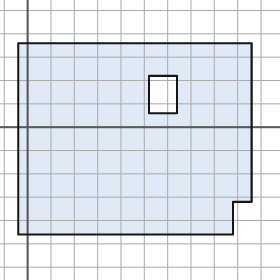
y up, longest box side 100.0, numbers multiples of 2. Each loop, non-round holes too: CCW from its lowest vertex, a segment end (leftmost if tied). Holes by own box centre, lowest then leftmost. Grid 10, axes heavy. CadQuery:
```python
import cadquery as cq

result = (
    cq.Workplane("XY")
    .moveTo(-4.0, -46.0)
    .lineTo(88.0, -46.0)
    .lineTo(88.0, -32.0)
    .lineTo(96.0, -32.0)
    .lineTo(96.0, 36.0)
    .lineTo(-4.0, 36.0)
    .close()
    .moveTo(52.0, 6.0)
    .lineTo(64.0, 6.0)
    .lineTo(64.0, 22.0)
    .lineTo(52.0, 22.0)
    .close()
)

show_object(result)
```